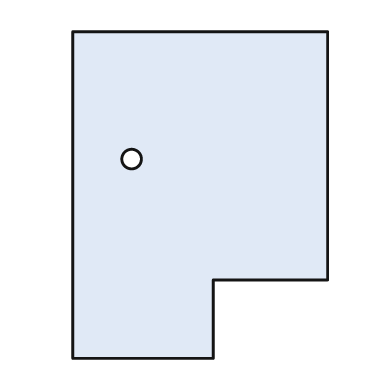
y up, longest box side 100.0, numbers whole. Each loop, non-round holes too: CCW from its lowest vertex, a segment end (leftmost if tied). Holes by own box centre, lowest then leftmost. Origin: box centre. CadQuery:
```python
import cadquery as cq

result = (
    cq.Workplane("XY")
    .moveTo(-39.0, -50.0)
    .lineTo(4.0, -50.0)
    .lineTo(4.0, -26.0)
    .lineTo(39.0, -26.0)
    .lineTo(39.0, 50.0)
    .lineTo(-39.0, 50.0)
    .close()
    .moveTo(-21.0, 11.0)
    .circle(3.0)
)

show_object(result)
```